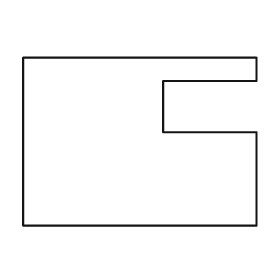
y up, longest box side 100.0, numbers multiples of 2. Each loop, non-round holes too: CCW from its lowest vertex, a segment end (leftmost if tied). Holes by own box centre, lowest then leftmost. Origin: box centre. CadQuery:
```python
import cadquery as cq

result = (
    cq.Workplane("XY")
    .moveTo(-50.0, -36.0)
    .lineTo(50.0, -36.0)
    .lineTo(50.0, 4.0)
    .lineTo(10.0, 4.0)
    .lineTo(10.0, 26.0)
    .lineTo(50.0, 26.0)
    .lineTo(50.0, 36.0)
    .lineTo(-50.0, 36.0)
    .close()
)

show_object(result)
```